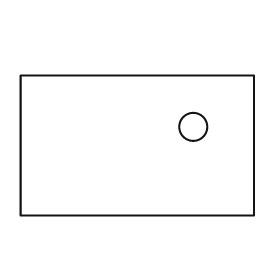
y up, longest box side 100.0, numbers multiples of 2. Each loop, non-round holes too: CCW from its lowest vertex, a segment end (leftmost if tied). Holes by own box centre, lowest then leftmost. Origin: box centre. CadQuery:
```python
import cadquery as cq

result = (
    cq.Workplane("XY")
    .moveTo(-50.0, -30.0)
    .lineTo(50.0, -30.0)
    .lineTo(50.0, 30.0)
    .lineTo(-50.0, 30.0)
    .close()
    .moveTo(24.0, 8.0)
    .circle(6.0)
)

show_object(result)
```